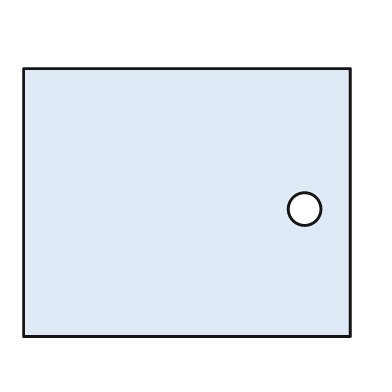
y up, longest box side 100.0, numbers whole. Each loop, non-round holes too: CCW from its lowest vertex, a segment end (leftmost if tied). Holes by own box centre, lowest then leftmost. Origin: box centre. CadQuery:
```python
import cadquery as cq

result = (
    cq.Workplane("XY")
    .moveTo(-50.0, -41.0)
    .lineTo(50.0, -41.0)
    .lineTo(50.0, 41.0)
    .lineTo(-50.0, 41.0)
    .close()
    .moveTo(36.0, -2.0)
    .circle(5.0)
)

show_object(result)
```